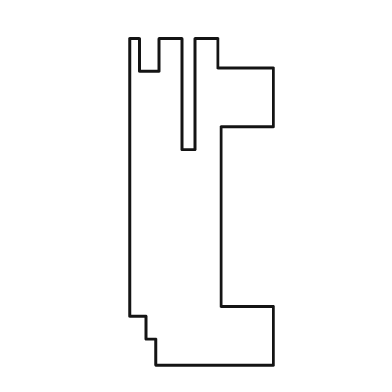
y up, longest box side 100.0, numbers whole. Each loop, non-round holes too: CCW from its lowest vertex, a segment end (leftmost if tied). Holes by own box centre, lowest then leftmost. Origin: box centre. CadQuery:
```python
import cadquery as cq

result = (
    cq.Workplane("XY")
    .moveTo(-14.0, -50.0)
    .lineTo(22.0, -50.0)
    .lineTo(22.0, -32.0)
    .lineTo(6.0, -32.0)
    .lineTo(6.0, 23.0)
    .lineTo(22.0, 23.0)
    .lineTo(22.0, 41.0)
    .lineTo(5.0, 41.0)
    .lineTo(5.0, 50.0)
    .lineTo(-2.0, 50.0)
    .lineTo(-2.0, 16.0)
    .lineTo(-6.0, 16.0)
    .lineTo(-6.0, 50.0)
    .lineTo(-13.0, 50.0)
    .lineTo(-13.0, 40.0)
    .lineTo(-19.0, 40.0)
    .lineTo(-19.0, 50.0)
    .lineTo(-22.0, 50.0)
    .lineTo(-22.0, -35.0)
    .lineTo(-17.0, -35.0)
    .lineTo(-17.0, -42.0)
    .lineTo(-14.0, -42.0)
    .close()
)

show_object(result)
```